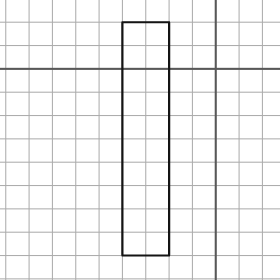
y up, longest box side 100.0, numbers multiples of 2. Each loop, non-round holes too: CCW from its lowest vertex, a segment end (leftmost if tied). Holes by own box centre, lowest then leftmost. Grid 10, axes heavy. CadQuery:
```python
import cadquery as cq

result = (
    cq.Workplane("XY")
    .moveTo(-40.0, -80.0)
    .lineTo(-20.0, -80.0)
    .lineTo(-20.0, 20.0)
    .lineTo(-40.0, 20.0)
    .close()
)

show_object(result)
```